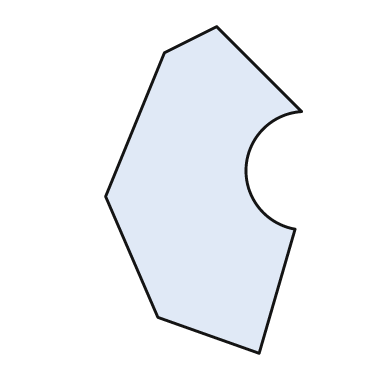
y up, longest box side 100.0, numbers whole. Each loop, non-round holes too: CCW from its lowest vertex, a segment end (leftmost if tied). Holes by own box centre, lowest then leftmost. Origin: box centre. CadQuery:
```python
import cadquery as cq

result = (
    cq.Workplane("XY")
    .moveTo(17.0, -50.0)
    .lineTo(28.0, -12.0)
    .threePointArc((13.0, 7.0), (30.0, 24.0))
    .lineTo(4.0, 50.0)
    .lineTo(-12.0, 42.0)
    .lineTo(-30.0, -2.0)
    .lineTo(-14.0, -39.0)
    .close()
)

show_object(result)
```